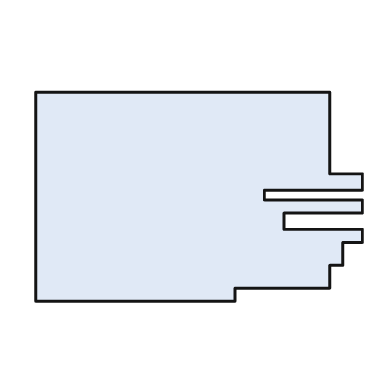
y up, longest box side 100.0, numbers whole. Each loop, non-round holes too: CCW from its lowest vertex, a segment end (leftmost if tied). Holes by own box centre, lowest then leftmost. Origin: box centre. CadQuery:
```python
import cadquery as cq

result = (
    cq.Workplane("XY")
    .moveTo(-50.0, -32.0)
    .lineTo(11.0, -32.0)
    .lineTo(11.0, -28.0)
    .lineTo(40.0, -28.0)
    .lineTo(40.0, -21.0)
    .lineTo(44.0, -21.0)
    .lineTo(44.0, -14.0)
    .lineTo(50.0, -14.0)
    .lineTo(50.0, -10.0)
    .lineTo(26.0, -10.0)
    .lineTo(26.0, -5.0)
    .lineTo(50.0, -5.0)
    .lineTo(50.0, -1.0)
    .lineTo(20.0, -1.0)
    .lineTo(20.0, 2.0)
    .lineTo(50.0, 2.0)
    .lineTo(50.0, 7.0)
    .lineTo(40.0, 7.0)
    .lineTo(40.0, 32.0)
    .lineTo(-50.0, 32.0)
    .close()
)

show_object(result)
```